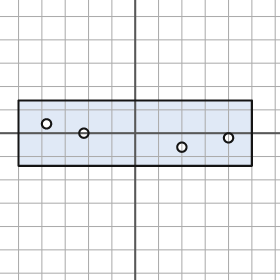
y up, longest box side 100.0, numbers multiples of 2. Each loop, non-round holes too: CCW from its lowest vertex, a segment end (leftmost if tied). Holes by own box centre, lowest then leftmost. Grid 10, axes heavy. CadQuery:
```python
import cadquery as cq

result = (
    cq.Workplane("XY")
    .moveTo(-50.0, -14.0)
    .lineTo(50.0, -14.0)
    .lineTo(50.0, 14.0)
    .lineTo(-50.0, 14.0)
    .close()
    .moveTo(20.0, -6.0)
    .circle(2.0)
    .moveTo(40.0, -2.0)
    .circle(2.0)
    .moveTo(-22.0, 0.0)
    .circle(2.0)
    .moveTo(-38.0, 4.0)
    .circle(2.0)
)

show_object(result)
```